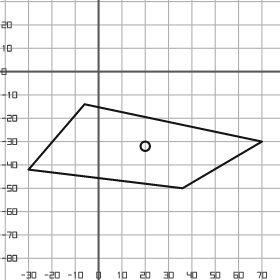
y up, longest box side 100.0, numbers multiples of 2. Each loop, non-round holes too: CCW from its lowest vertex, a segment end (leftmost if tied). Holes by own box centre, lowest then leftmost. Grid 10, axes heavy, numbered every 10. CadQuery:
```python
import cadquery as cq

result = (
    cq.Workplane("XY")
    .moveTo(36.0, -50.0)
    .lineTo(70.0, -30.0)
    .lineTo(-6.0, -14.0)
    .lineTo(-30.0, -42.0)
    .close()
    .moveTo(20.0, -32.0)
    .circle(2.0)
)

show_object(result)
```